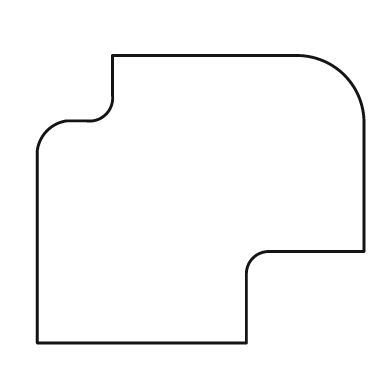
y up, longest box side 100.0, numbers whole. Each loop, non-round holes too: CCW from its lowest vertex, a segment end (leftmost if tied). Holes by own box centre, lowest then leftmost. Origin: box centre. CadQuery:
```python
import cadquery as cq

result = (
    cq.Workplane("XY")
    .moveTo(-50.0, -44.0)
    .lineTo(14.0, -44.0)
    .lineTo(14.0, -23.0)
    .threePointArc((16.0, -18.0), (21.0, -16.0))
    .lineTo(50.0, -16.0)
    .lineTo(50.0, 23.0)
    .threePointArc((44.0, 38.0), (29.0, 44.0))
    .lineTo(-27.0, 44.0)
    .lineTo(-27.0, 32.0)
    .threePointArc((-29.0, 26.0), (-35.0, 24.0))
    .lineTo(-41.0, 24.0)
    .threePointArc((-47.0, 21.0), (-50.0, 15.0))
    .close()
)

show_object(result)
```